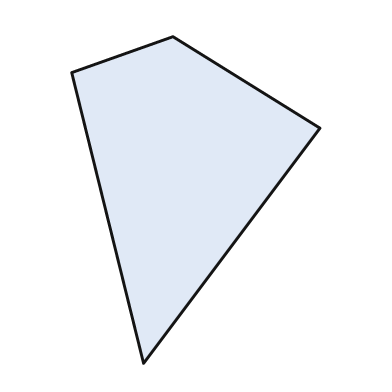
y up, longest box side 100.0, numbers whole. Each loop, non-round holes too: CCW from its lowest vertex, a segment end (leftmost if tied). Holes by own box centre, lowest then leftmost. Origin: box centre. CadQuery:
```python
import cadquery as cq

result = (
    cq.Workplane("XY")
    .moveTo(-16.0, -50.0)
    .lineTo(38.0, 22.0)
    .lineTo(-7.0, 50.0)
    .lineTo(-38.0, 39.0)
    .close()
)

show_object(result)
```